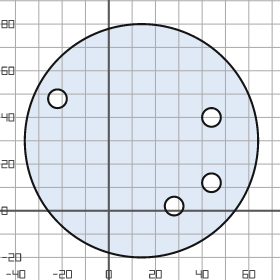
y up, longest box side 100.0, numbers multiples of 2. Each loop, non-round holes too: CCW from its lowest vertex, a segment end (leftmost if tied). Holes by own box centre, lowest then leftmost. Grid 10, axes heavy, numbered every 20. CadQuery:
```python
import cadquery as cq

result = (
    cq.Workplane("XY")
    .moveTo(14.0, 30.0)
    .circle(50.0)
    .moveTo(28.0, 2.0)
    .circle(4.0)
    .moveTo(44.0, 12.0)
    .circle(4.0)
    .moveTo(44.0, 40.0)
    .circle(4.0)
    .moveTo(-22.0, 48.0)
    .circle(4.0)
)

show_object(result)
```